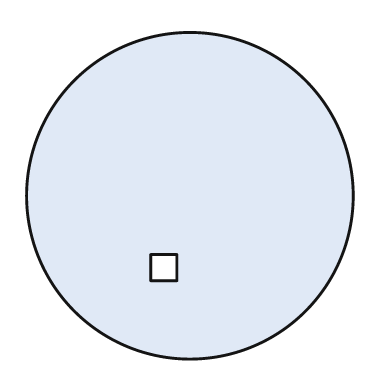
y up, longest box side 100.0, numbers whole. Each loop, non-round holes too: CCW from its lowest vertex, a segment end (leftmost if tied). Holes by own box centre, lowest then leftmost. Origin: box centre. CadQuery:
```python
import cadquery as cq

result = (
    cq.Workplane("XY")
    .moveTo(0.0, 0.0)
    .circle(50.0)
    .moveTo(-12.0, -26.0)
    .lineTo(-4.0, -26.0)
    .lineTo(-4.0, -18.0)
    .lineTo(-12.0, -18.0)
    .close()
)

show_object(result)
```